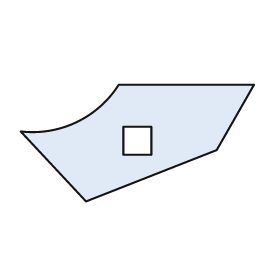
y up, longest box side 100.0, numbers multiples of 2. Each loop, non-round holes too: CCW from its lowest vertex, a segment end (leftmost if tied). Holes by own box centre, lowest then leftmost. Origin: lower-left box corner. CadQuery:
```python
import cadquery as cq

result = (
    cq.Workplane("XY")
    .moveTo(28.0, 0.0)
    .lineTo(84.0, 22.0)
    .lineTo(100.0, 50.0)
    .lineTo(42.0, 50.0)
    .threePointArc((24.0, 34.0), (0.0, 30.0))
    .close()
    .moveTo(44.0, 20.0)
    .lineTo(56.0, 20.0)
    .lineTo(56.0, 32.0)
    .lineTo(44.0, 32.0)
    .close()
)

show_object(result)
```